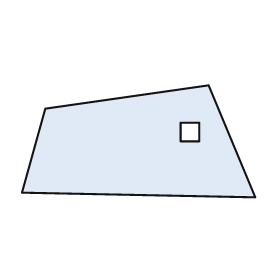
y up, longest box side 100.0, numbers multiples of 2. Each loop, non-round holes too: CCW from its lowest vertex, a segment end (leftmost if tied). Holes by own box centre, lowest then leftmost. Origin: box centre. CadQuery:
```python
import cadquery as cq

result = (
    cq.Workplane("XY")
    .moveTo(50.0, -24.0)
    .lineTo(30.0, 24.0)
    .lineTo(-40.0, 14.0)
    .lineTo(-50.0, -22.0)
    .close()
    .moveTo(18.0, 0.0)
    .lineTo(26.0, 0.0)
    .lineTo(26.0, 8.0)
    .lineTo(18.0, 8.0)
    .close()
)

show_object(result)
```